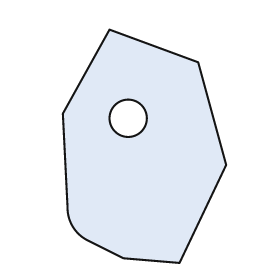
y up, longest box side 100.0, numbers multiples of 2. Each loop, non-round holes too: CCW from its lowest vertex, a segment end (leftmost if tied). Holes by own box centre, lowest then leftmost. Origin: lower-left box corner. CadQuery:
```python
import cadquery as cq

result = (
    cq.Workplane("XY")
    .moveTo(50.0, 0.0)
    .lineTo(70.0, 42.0)
    .lineTo(58.0, 86.0)
    .lineTo(20.0, 100.0)
    .lineTo(0.0, 64.0)
    .lineTo(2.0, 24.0)
    .threePointArc((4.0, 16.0), (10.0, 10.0))
    .lineTo(26.0, 2.0)
    .close()
    .moveTo(28.0, 62.0)
    .circle(8.0)
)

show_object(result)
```